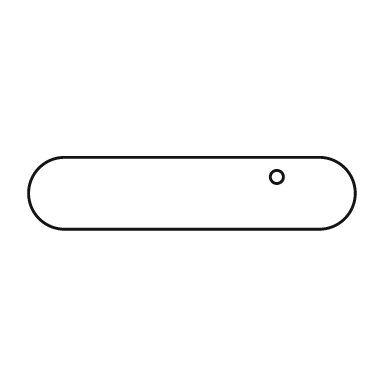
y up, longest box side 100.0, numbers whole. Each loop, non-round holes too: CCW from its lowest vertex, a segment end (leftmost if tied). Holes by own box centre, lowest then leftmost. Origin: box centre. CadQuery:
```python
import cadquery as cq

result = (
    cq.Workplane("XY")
    .moveTo(-39.0, -11.0)
    .lineTo(39.0, -11.0)
    .threePointArc((50.0, 0.0), (39.0, 11.0))
    .lineTo(-39.0, 11.0)
    .threePointArc((-50.0, 0.0), (-39.0, -11.0))
    .close()
    .moveTo(26.0, 5.0)
    .circle(2.0)
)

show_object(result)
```